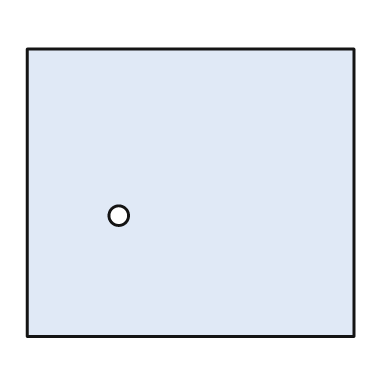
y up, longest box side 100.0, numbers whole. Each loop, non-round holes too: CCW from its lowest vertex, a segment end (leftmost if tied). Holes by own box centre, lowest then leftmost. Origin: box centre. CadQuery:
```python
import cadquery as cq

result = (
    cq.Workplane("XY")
    .moveTo(-50.0, -44.0)
    .lineTo(50.0, -44.0)
    .lineTo(50.0, 44.0)
    .lineTo(-50.0, 44.0)
    .close()
    .moveTo(-22.0, -7.0)
    .circle(3.0)
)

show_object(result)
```